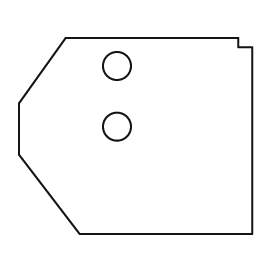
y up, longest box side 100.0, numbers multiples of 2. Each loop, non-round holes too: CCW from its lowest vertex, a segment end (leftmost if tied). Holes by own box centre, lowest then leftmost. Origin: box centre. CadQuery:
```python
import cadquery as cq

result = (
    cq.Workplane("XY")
    .moveTo(-24.0, -42.0)
    .lineTo(50.0, -42.0)
    .lineTo(50.0, 38.0)
    .lineTo(44.0, 38.0)
    .lineTo(44.0, 42.0)
    .lineTo(-30.0, 42.0)
    .lineTo(-50.0, 14.0)
    .lineTo(-50.0, -8.0)
    .close()
    .moveTo(-8.0, 4.0)
    .circle(6.0)
    .moveTo(-8.0, 30.0)
    .circle(6.0)
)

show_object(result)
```